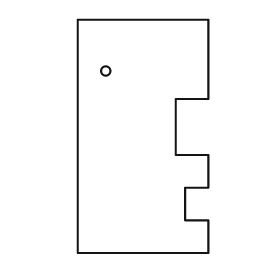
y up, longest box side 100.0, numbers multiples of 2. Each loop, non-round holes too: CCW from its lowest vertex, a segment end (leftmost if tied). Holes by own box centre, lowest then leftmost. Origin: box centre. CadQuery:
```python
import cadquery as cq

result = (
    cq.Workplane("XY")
    .moveTo(-28.0, -50.0)
    .lineTo(28.0, -50.0)
    .lineTo(28.0, -36.0)
    .lineTo(18.0, -36.0)
    .lineTo(18.0, -22.0)
    .lineTo(28.0, -22.0)
    .lineTo(28.0, -8.0)
    .lineTo(14.0, -8.0)
    .lineTo(14.0, 16.0)
    .lineTo(28.0, 16.0)
    .lineTo(28.0, 50.0)
    .lineTo(-28.0, 50.0)
    .close()
    .moveTo(-16.0, 28.0)
    .circle(2.0)
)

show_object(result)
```